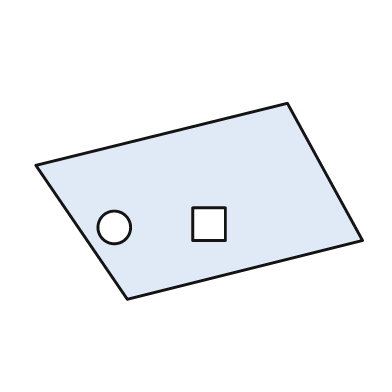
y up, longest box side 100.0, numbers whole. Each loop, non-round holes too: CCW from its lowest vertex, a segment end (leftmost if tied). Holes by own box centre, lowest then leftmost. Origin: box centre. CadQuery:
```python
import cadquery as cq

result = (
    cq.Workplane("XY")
    .moveTo(-22.0, -30.0)
    .lineTo(50.0, -12.0)
    .lineTo(27.0, 30.0)
    .lineTo(-50.0, 11.0)
    .close()
    .moveTo(-26.0, -8.0)
    .circle(5.0)
    .moveTo(-2.0, -12.0)
    .lineTo(8.0, -12.0)
    .lineTo(8.0, -2.0)
    .lineTo(-2.0, -2.0)
    .close()
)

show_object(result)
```